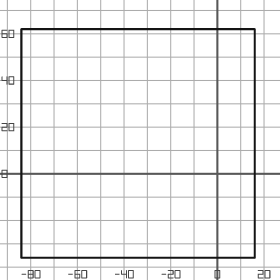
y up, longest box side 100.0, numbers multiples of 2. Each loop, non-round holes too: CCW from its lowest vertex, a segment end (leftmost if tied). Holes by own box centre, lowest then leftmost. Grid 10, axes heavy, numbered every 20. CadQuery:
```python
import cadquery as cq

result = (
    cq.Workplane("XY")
    .moveTo(-84.0, -36.0)
    .lineTo(16.0, -36.0)
    .lineTo(16.0, 62.0)
    .lineTo(-84.0, 62.0)
    .close()
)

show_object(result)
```